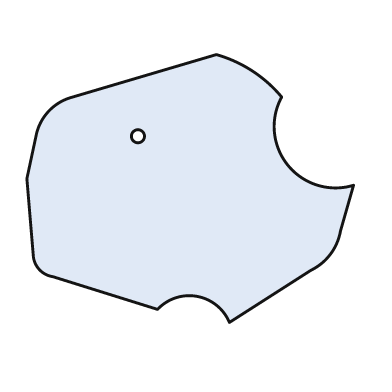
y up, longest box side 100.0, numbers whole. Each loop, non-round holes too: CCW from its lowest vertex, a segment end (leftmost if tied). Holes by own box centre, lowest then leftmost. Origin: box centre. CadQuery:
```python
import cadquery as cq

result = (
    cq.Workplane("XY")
    .moveTo(12.0, -41.0)
    .lineTo(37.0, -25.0)
    .threePointArc((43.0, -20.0), (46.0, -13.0))
    .lineTo(50.0, 1.0)
    .threePointArc((30.0, 7.0), (28.0, 28.0))
    .threePointArc((19.0, 36.0), (8.0, 41.0))
    .lineTo(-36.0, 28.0)
    .threePointArc((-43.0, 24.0), (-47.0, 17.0))
    .lineTo(-50.0, 3.0)
    .lineTo(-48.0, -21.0)
    .threePointArc((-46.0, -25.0), (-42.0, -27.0))
    .lineTo(-10.0, -37.0)
    .threePointArc((2.0, -33.0), (12.0, -41.0))
    .close()
    .moveTo(-16.0, 16.0)
    .circle(2.0)
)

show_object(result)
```